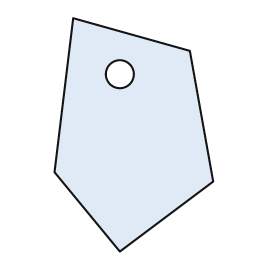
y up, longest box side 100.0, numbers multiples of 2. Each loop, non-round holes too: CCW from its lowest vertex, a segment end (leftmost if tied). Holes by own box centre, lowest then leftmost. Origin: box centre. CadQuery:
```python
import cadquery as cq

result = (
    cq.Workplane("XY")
    .moveTo(-6.0, -50.0)
    .lineTo(34.0, -20.0)
    .lineTo(24.0, 36.0)
    .lineTo(-26.0, 50.0)
    .lineTo(-34.0, -16.0)
    .close()
    .moveTo(-6.0, 26.0)
    .circle(6.0)
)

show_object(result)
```